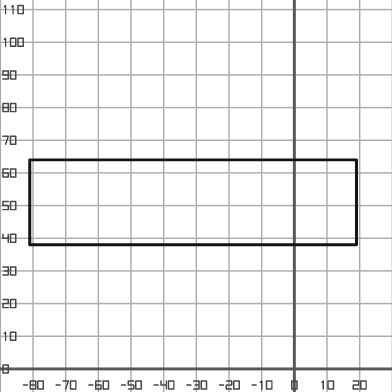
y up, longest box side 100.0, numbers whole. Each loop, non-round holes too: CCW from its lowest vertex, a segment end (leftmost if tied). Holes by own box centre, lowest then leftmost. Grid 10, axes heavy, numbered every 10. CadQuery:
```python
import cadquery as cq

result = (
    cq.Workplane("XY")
    .moveTo(-81.0, 38.0)
    .lineTo(19.0, 38.0)
    .lineTo(19.0, 64.0)
    .lineTo(-81.0, 64.0)
    .close()
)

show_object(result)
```